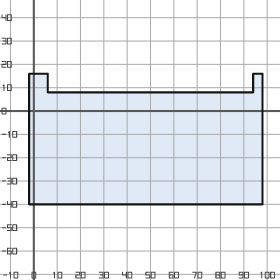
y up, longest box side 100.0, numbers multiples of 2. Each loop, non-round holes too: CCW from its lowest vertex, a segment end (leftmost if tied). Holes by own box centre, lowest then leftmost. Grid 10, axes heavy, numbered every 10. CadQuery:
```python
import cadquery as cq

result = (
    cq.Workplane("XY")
    .moveTo(-2.0, -40.0)
    .lineTo(98.0, -40.0)
    .lineTo(98.0, 16.0)
    .lineTo(94.0, 16.0)
    .lineTo(94.0, 8.0)
    .lineTo(6.0, 8.0)
    .lineTo(6.0, 16.0)
    .lineTo(-2.0, 16.0)
    .close()
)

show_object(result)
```